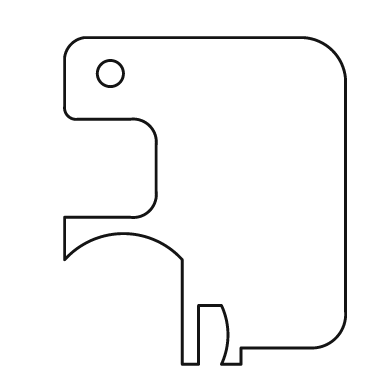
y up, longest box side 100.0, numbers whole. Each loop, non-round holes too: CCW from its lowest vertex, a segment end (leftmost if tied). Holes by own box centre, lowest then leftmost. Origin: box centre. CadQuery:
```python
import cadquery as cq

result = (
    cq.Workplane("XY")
    .moveTo(-7.0, -50.0)
    .lineTo(-2.0, -50.0)
    .lineTo(-2.0, -32.0)
    .lineTo(5.0, -32.0)
    .threePointArc((7.0, -41.0), (5.0, -50.0))
    .lineTo(11.0, -50.0)
    .lineTo(11.0, -45.0)
    .lineTo(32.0, -45.0)
    .threePointArc((40.0, -42.0), (43.0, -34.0))
    .lineTo(43.0, 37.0)
    .threePointArc((39.0, 46.0), (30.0, 50.0))
    .lineTo(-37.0, 50.0)
    .threePointArc((-41.0, 48.0), (-43.0, 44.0))
    .lineTo(-43.0, 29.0)
    .threePointArc((-42.0, 26.0), (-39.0, 25.0))
    .lineTo(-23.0, 25.0)
    .threePointArc((-17.0, 23.0), (-15.0, 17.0))
    .lineTo(-15.0, 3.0)
    .threePointArc((-17.0, -3.0), (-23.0, -5.0))
    .lineTo(-43.0, -5.0)
    .lineTo(-43.0, -18.0)
    .threePointArc((-25.0, -10.0), (-7.0, -18.0))
    .close()
    .moveTo(-29.0, 39.0)
    .circle(4.0)
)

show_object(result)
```